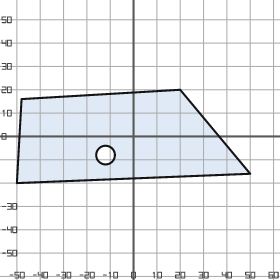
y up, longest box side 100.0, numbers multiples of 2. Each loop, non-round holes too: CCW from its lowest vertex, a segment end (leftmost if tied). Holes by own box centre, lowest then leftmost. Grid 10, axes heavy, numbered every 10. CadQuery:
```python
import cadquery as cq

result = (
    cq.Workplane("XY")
    .moveTo(-50.0, -20.0)
    .lineTo(50.0, -16.0)
    .lineTo(20.0, 20.0)
    .lineTo(-48.0, 16.0)
    .close()
    .moveTo(-12.0, -8.0)
    .circle(4.0)
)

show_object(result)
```